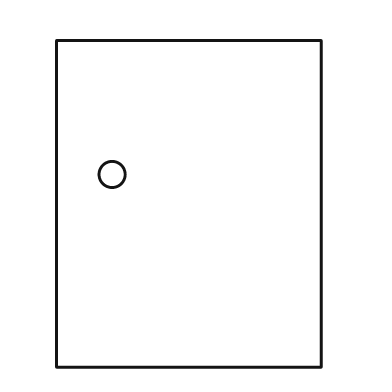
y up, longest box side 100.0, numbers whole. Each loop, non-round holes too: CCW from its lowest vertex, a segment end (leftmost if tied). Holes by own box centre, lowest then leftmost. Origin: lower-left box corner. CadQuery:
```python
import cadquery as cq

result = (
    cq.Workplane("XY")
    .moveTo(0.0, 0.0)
    .lineTo(81.0, 0.0)
    .lineTo(81.0, 100.0)
    .lineTo(0.0, 100.0)
    .close()
    .moveTo(17.0, 59.0)
    .circle(4.0)
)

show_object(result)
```